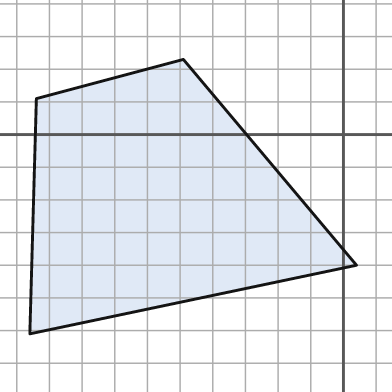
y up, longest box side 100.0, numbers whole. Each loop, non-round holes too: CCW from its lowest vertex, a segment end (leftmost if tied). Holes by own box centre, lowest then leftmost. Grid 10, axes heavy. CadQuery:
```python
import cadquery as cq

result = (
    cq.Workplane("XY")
    .moveTo(-96.0, -61.0)
    .lineTo(4.0, -40.0)
    .lineTo(-49.0, 23.0)
    .lineTo(-94.0, 11.0)
    .close()
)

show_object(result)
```